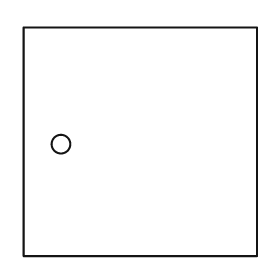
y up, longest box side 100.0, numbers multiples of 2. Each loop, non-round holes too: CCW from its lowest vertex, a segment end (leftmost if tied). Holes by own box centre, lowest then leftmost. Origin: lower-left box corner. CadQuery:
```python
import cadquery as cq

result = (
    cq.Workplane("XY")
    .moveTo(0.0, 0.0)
    .lineTo(100.0, 0.0)
    .lineTo(100.0, 98.0)
    .lineTo(0.0, 98.0)
    .close()
    .moveTo(16.0, 48.0)
    .circle(4.0)
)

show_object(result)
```